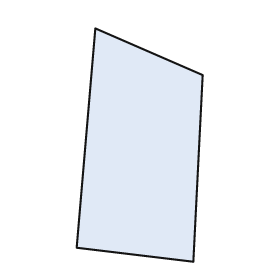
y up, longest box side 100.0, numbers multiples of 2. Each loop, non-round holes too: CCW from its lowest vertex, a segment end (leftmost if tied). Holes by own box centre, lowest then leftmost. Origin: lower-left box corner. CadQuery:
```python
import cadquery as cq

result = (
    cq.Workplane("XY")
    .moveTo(50.0, 0.0)
    .lineTo(54.0, 80.0)
    .lineTo(8.0, 100.0)
    .lineTo(0.0, 6.0)
    .close()
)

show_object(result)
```